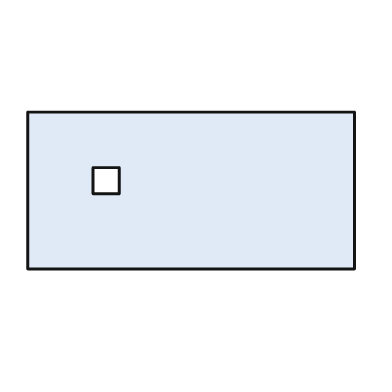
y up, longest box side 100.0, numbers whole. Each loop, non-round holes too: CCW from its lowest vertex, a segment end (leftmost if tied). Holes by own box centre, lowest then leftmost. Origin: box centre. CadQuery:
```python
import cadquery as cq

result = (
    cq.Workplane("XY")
    .moveTo(-50.0, -24.0)
    .lineTo(50.0, -24.0)
    .lineTo(50.0, 24.0)
    .lineTo(-50.0, 24.0)
    .close()
    .moveTo(-30.0, -1.0)
    .lineTo(-22.0, -1.0)
    .lineTo(-22.0, 7.0)
    .lineTo(-30.0, 7.0)
    .close()
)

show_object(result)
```